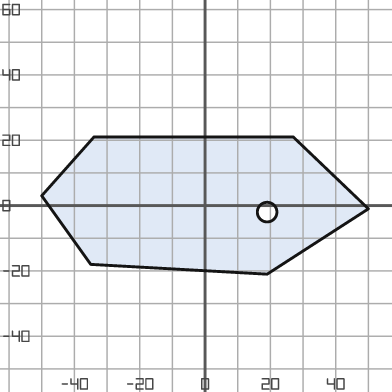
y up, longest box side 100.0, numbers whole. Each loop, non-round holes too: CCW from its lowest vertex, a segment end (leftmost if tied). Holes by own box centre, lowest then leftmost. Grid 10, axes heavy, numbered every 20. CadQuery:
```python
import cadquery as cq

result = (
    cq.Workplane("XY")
    .moveTo(19.0, -21.0)
    .lineTo(50.0, -1.0)
    .lineTo(27.0, 21.0)
    .lineTo(-34.0, 21.0)
    .lineTo(-50.0, 3.0)
    .lineTo(-35.0, -18.0)
    .close()
    .moveTo(19.0, -2.0)
    .circle(3.0)
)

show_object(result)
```